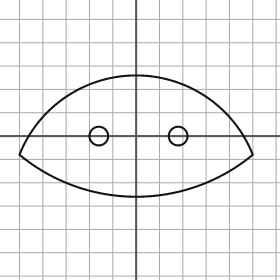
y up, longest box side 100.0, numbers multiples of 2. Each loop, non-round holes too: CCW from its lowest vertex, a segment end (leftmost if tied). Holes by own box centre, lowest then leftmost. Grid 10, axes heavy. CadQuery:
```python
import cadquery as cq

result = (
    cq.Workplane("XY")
    .moveTo(-50.0, -8.0)
    .threePointArc((0.0, -26.0), (50.0, -8.0))
    .threePointArc((0.0, 26.0), (-50.0, -8.0))
    .close()
    .moveTo(-16.0, 0.0)
    .circle(4.0)
    .moveTo(18.0, 0.0)
    .circle(4.0)
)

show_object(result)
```